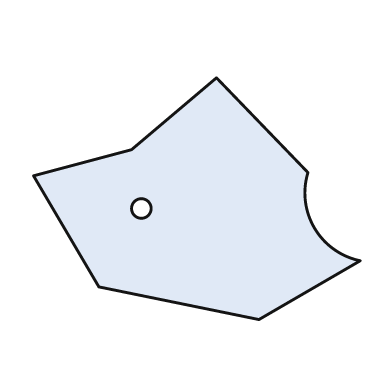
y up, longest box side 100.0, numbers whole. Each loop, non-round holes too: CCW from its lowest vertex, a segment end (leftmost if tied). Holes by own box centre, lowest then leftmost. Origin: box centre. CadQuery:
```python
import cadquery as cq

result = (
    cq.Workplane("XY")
    .moveTo(19.0, -37.0)
    .lineTo(50.0, -19.0)
    .threePointArc((36.0, -9.0), (34.0, 8.0))
    .lineTo(6.0, 37.0)
    .lineTo(-20.0, 15.0)
    .lineTo(-50.0, 7.0)
    .lineTo(-30.0, -27.0)
    .close()
    .moveTo(-17.0, -3.0)
    .circle(3.0)
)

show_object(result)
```